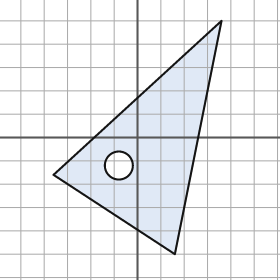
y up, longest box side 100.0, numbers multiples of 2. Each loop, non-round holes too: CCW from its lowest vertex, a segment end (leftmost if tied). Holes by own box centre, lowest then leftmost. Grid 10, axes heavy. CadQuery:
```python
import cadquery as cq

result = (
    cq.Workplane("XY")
    .moveTo(16.0, -50.0)
    .lineTo(36.0, 50.0)
    .lineTo(-36.0, -16.0)
    .close()
    .moveTo(-8.0, -12.0)
    .circle(6.0)
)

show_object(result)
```